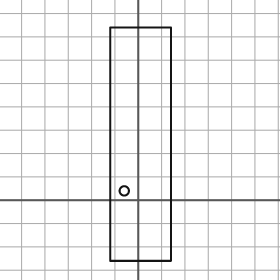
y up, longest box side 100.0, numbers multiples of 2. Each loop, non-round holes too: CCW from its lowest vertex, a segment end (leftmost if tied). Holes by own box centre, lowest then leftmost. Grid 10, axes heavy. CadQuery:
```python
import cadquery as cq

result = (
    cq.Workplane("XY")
    .moveTo(-12.0, -26.0)
    .lineTo(14.0, -26.0)
    .lineTo(14.0, 74.0)
    .lineTo(-12.0, 74.0)
    .close()
    .moveTo(-6.0, 4.0)
    .circle(2.0)
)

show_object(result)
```